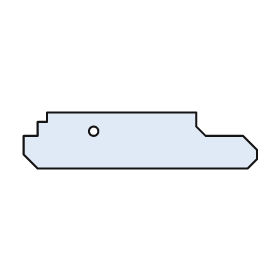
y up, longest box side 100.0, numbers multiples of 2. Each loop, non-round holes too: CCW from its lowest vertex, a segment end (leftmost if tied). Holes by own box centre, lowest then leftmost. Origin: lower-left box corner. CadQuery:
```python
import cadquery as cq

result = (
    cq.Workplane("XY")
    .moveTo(6.0, 0.0)
    .lineTo(96.0, 0.0)
    .lineTo(100.0, 4.0)
    .lineTo(100.0, 8.0)
    .lineTo(94.0, 14.0)
    .lineTo(78.0, 14.0)
    .lineTo(74.0, 18.0)
    .lineTo(74.0, 24.0)
    .lineTo(10.0, 24.0)
    .lineTo(10.0, 20.0)
    .lineTo(6.0, 20.0)
    .lineTo(6.0, 14.0)
    .lineTo(0.0, 14.0)
    .lineTo(0.0, 6.0)
    .close()
    .moveTo(30.0, 16.0)
    .circle(2.0)
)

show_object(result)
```